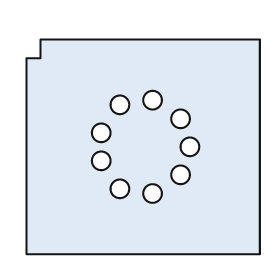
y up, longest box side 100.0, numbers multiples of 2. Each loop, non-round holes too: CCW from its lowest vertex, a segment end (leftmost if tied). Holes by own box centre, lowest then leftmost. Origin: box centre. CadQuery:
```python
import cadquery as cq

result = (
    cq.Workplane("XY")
    .moveTo(-50.0, -46.0)
    .lineTo(50.0, -46.0)
    .lineTo(50.0, 46.0)
    .lineTo(-44.0, 46.0)
    .lineTo(-44.0, 38.0)
    .lineTo(-50.0, 38.0)
    .close()
    .moveTo(4.0, -20.0)
    .circle(4.0)
    .moveTo(-10.0, -18.0)
    .circle(4.0)
    .moveTo(16.0, -12.0)
    .circle(4.0)
    .moveTo(-18.0, -6.0)
    .circle(4.0)
    .moveTo(20.0, 0.0)
    .circle(4.0)
    .moveTo(-18.0, 6.0)
    .circle(4.0)
    .moveTo(16.0, 12.0)
    .circle(4.0)
    .moveTo(-10.0, 18.0)
    .circle(4.0)
    .moveTo(4.0, 20.0)
    .circle(4.0)
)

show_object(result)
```